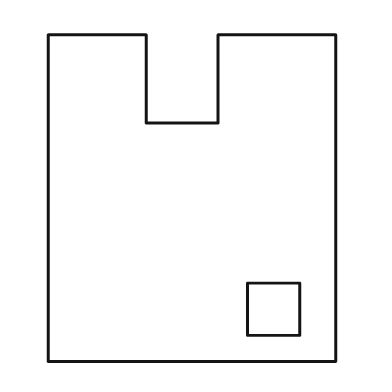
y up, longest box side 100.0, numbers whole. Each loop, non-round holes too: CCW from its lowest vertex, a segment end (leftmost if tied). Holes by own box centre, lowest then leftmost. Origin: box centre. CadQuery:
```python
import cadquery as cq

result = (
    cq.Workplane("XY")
    .moveTo(-44.0, -50.0)
    .lineTo(44.0, -50.0)
    .lineTo(44.0, 50.0)
    .lineTo(8.0, 50.0)
    .lineTo(8.0, 23.0)
    .lineTo(-14.0, 23.0)
    .lineTo(-14.0, 50.0)
    .lineTo(-44.0, 50.0)
    .close()
    .moveTo(17.0, -42.0)
    .lineTo(33.0, -42.0)
    .lineTo(33.0, -26.0)
    .lineTo(17.0, -26.0)
    .close()
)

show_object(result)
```